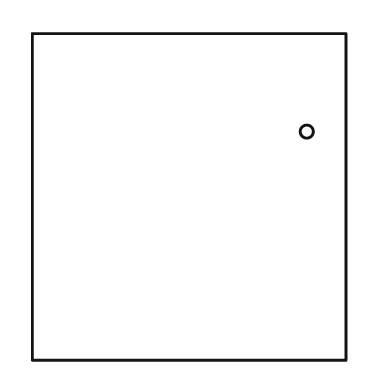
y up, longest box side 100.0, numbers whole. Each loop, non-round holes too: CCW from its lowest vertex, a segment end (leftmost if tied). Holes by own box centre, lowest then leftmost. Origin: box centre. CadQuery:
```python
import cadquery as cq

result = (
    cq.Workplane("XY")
    .moveTo(-48.0, -50.0)
    .lineTo(48.0, -50.0)
    .lineTo(48.0, 50.0)
    .lineTo(-48.0, 50.0)
    .close()
    .moveTo(36.0, 20.0)
    .circle(2.0)
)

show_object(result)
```